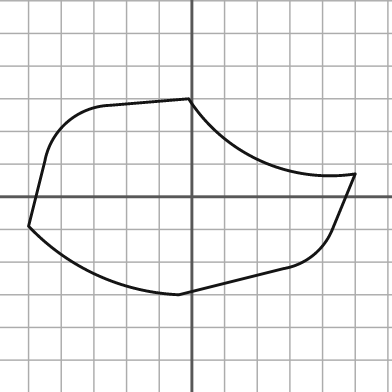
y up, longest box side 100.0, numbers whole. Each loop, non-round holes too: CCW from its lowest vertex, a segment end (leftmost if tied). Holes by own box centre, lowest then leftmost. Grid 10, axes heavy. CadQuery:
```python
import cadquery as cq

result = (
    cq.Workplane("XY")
    .moveTo(-4.0, -30.0)
    .lineTo(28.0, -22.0)
    .threePointArc((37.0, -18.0), (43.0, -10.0))
    .lineTo(50.0, 7.0)
    .threePointArc((21.0, 11.0), (-1.0, 30.0))
    .lineTo(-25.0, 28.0)
    .threePointArc((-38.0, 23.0), (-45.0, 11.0))
    .lineTo(-50.0, -9.0)
    .threePointArc((-29.0, -24.0), (-4.0, -30.0))
    .close()
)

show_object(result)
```